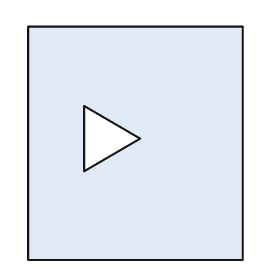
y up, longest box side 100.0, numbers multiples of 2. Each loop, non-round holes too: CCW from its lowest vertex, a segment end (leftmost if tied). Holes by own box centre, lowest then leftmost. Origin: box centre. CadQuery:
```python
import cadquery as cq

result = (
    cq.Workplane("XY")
    .moveTo(-46.0, -50.0)
    .lineTo(46.0, -50.0)
    .lineTo(46.0, 50.0)
    .lineTo(-46.0, 50.0)
    .close()
    .moveTo(-22.0, -12.0)
    .lineTo(2.0, 2.0)
    .lineTo(-22.0, 16.0)
    .close()
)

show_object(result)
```